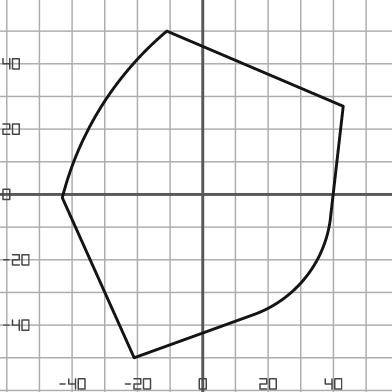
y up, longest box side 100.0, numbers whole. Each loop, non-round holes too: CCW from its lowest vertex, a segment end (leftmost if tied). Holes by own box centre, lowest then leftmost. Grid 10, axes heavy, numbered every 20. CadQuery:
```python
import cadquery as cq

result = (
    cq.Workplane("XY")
    .moveTo(-21.0, -50.0)
    .lineTo(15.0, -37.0)
    .threePointArc((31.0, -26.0), (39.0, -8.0))
    .lineTo(43.0, 27.0)
    .lineTo(-11.0, 50.0)
    .threePointArc((-31.0, 27.0), (-43.0, -1.0))
    .close()
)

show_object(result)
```